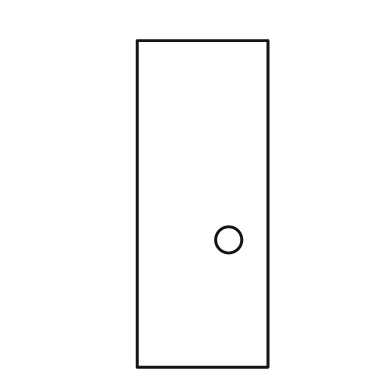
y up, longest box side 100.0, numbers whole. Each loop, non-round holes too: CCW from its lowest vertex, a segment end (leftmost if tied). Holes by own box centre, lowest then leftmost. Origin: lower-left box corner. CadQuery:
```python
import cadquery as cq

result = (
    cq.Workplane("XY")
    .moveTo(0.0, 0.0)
    .lineTo(40.0, 0.0)
    .lineTo(40.0, 100.0)
    .lineTo(0.0, 100.0)
    .close()
    .moveTo(28.0, 39.0)
    .circle(4.0)
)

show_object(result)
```